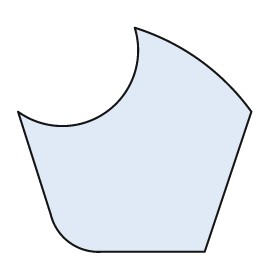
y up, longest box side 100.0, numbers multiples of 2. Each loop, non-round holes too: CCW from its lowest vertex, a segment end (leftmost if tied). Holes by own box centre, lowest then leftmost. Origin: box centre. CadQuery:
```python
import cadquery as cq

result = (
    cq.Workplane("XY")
    .moveTo(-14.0, -48.0)
    .lineTo(30.0, -48.0)
    .lineTo(50.0, 12.0)
    .threePointArc((28.0, 34.0), (0.0, 48.0))
    .threePointArc((-12.0, 12.0), (-50.0, 12.0))
    .lineTo(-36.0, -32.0)
    .threePointArc((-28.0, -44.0), (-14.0, -48.0))
    .close()
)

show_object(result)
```